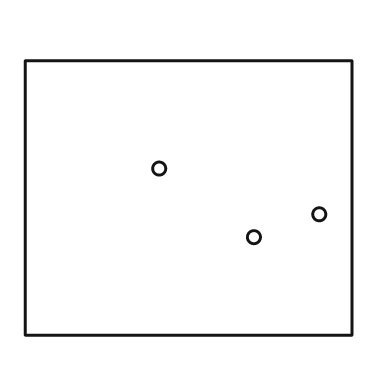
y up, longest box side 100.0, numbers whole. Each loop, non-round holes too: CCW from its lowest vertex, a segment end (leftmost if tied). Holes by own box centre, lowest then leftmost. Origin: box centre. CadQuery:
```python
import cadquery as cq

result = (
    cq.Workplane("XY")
    .moveTo(-50.0, -42.0)
    .lineTo(50.0, -42.0)
    .lineTo(50.0, 42.0)
    .lineTo(-50.0, 42.0)
    .close()
    .moveTo(20.0, -12.0)
    .circle(2.0)
    .moveTo(40.0, -5.0)
    .circle(2.0)
    .moveTo(-9.0, 9.0)
    .circle(2.0)
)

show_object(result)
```